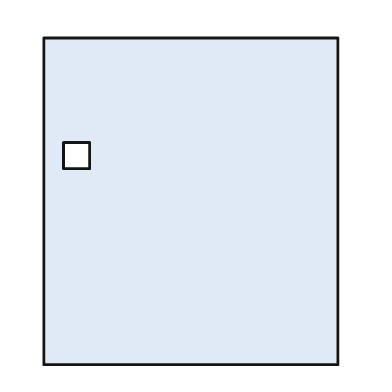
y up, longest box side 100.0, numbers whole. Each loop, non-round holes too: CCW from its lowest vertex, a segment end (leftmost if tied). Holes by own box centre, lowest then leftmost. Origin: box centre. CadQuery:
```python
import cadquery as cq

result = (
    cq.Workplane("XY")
    .moveTo(-45.0, -50.0)
    .lineTo(45.0, -50.0)
    .lineTo(45.0, 50.0)
    .lineTo(-45.0, 50.0)
    .close()
    .moveTo(-39.0, 10.0)
    .lineTo(-31.0, 10.0)
    .lineTo(-31.0, 18.0)
    .lineTo(-39.0, 18.0)
    .close()
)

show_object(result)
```